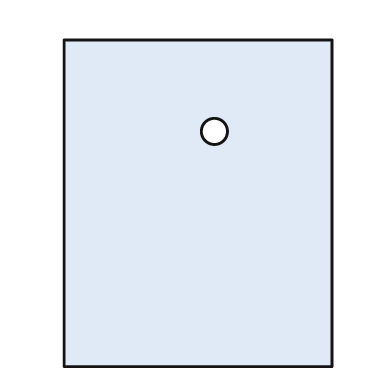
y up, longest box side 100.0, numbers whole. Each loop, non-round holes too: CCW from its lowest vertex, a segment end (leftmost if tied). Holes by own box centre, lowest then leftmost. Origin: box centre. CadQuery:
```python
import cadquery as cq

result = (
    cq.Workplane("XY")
    .moveTo(-41.0, -50.0)
    .lineTo(41.0, -50.0)
    .lineTo(41.0, 50.0)
    .lineTo(-41.0, 50.0)
    .close()
    .moveTo(5.0, 22.0)
    .circle(4.0)
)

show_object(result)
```